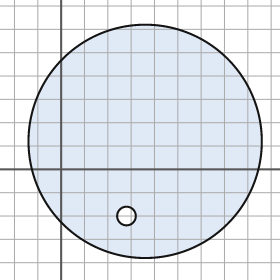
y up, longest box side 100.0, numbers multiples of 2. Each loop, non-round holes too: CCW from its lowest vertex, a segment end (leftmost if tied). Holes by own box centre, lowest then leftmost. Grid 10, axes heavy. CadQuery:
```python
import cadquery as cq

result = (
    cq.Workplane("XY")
    .moveTo(36.0, 12.0)
    .circle(50.0)
    .moveTo(28.0, -20.0)
    .circle(4.0)
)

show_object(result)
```